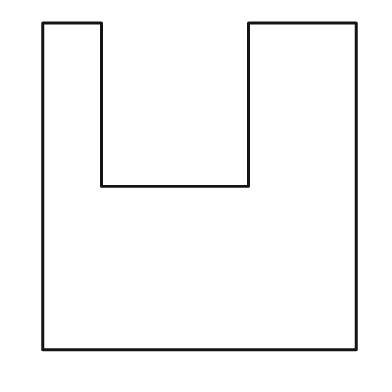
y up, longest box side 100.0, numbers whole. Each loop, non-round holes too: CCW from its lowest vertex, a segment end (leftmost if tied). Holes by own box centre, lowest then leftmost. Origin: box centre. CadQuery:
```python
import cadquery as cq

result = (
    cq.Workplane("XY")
    .moveTo(-48.0, -50.0)
    .lineTo(48.0, -50.0)
    .lineTo(48.0, 50.0)
    .lineTo(15.0, 50.0)
    .lineTo(15.0, 0.0)
    .lineTo(-30.0, 0.0)
    .lineTo(-30.0, 50.0)
    .lineTo(-48.0, 50.0)
    .close()
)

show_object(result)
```